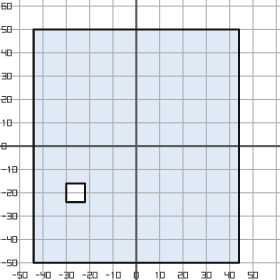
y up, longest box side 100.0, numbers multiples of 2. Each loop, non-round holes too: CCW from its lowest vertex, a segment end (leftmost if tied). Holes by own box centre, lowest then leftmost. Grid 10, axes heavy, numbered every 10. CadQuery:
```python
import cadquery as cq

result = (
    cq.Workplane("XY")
    .moveTo(-44.0, -50.0)
    .lineTo(44.0, -50.0)
    .lineTo(44.0, 50.0)
    .lineTo(-44.0, 50.0)
    .close()
    .moveTo(-30.0, -24.0)
    .lineTo(-22.0, -24.0)
    .lineTo(-22.0, -16.0)
    .lineTo(-30.0, -16.0)
    .close()
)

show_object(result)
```